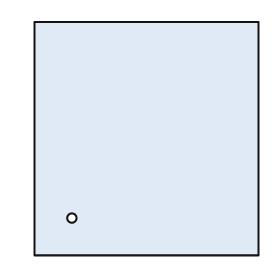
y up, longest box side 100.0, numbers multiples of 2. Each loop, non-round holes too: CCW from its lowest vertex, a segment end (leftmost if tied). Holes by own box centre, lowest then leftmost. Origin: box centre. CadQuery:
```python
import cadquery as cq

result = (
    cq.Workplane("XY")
    .moveTo(-48.0, -50.0)
    .lineTo(48.0, -50.0)
    .lineTo(48.0, 50.0)
    .lineTo(-48.0, 50.0)
    .close()
    .moveTo(-32.0, -34.0)
    .circle(2.0)
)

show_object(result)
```